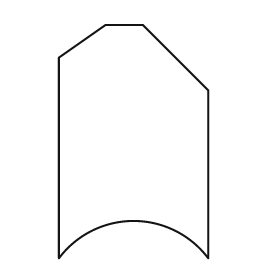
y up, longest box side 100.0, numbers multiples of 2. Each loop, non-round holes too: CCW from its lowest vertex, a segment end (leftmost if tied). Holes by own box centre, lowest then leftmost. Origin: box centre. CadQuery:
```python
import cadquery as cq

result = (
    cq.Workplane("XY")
    .moveTo(-32.0, -50.0)
    .threePointArc((0.0, -34.0), (32.0, -50.0))
    .lineTo(32.0, 22.0)
    .lineTo(4.0, 50.0)
    .lineTo(-12.0, 50.0)
    .lineTo(-32.0, 36.0)
    .close()
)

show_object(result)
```